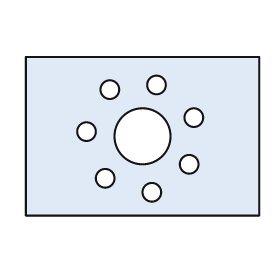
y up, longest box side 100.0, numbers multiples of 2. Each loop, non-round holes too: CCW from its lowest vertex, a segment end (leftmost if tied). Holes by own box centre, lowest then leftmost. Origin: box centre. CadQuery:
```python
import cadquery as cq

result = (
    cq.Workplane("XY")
    .moveTo(-50.0, -34.0)
    .lineTo(50.0, -34.0)
    .lineTo(50.0, 34.0)
    .lineTo(-50.0, 34.0)
    .close()
    .moveTo(4.0, -24.0)
    .circle(4.0)
    .moveTo(-16.0, -18.0)
    .circle(4.0)
    .moveTo(20.0, -12.0)
    .circle(4.0)
    .moveTo(0.0, 0.0)
    .circle(12.0)
    .moveTo(-24.0, 2.0)
    .circle(4.0)
    .moveTo(22.0, 8.0)
    .circle(4.0)
    .moveTo(-14.0, 20.0)
    .circle(4.0)
    .moveTo(6.0, 22.0)
    .circle(4.0)
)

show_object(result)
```